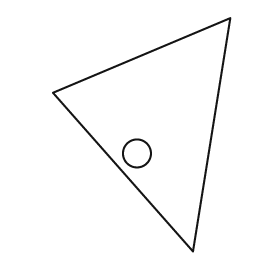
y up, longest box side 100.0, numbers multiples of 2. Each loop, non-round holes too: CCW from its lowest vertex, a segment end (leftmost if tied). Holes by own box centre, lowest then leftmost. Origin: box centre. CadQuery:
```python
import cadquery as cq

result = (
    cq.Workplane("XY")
    .moveTo(22.0, -50.0)
    .lineTo(38.0, 50.0)
    .lineTo(-38.0, 18.0)
    .close()
    .moveTo(-2.0, -8.0)
    .circle(6.0)
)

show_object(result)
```